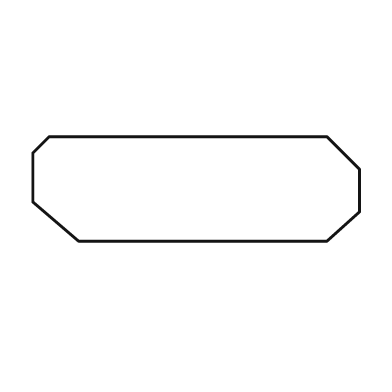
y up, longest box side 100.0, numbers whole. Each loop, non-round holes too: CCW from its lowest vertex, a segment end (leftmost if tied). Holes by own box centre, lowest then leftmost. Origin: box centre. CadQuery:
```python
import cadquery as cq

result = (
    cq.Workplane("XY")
    .moveTo(-36.0, -16.0)
    .lineTo(40.0, -16.0)
    .lineTo(50.0, -7.0)
    .lineTo(50.0, 6.0)
    .lineTo(40.0, 16.0)
    .lineTo(-45.0, 16.0)
    .lineTo(-50.0, 11.0)
    .lineTo(-50.0, -4.0)
    .close()
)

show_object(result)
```